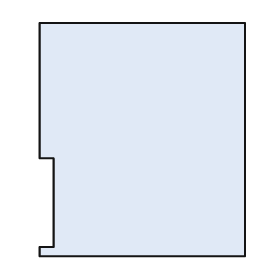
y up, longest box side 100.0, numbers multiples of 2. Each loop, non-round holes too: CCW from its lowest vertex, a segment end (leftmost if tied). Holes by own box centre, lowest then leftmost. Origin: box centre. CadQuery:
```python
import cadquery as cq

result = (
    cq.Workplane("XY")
    .moveTo(-44.0, -50.0)
    .lineTo(44.0, -50.0)
    .lineTo(44.0, 50.0)
    .lineTo(-44.0, 50.0)
    .lineTo(-44.0, -8.0)
    .lineTo(-38.0, -8.0)
    .lineTo(-38.0, -46.0)
    .lineTo(-44.0, -46.0)
    .close()
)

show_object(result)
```